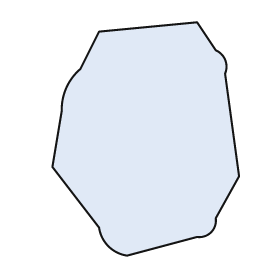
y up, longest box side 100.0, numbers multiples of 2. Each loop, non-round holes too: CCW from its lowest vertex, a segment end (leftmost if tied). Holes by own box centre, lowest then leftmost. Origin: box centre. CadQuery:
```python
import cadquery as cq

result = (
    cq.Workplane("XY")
    .moveTo(-8.0, -50.0)
    .lineTo(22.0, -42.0)
    .threePointArc((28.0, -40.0), (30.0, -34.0))
    .lineTo(40.0, -16.0)
    .lineTo(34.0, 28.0)
    .threePointArc((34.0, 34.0), (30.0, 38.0))
    .lineTo(22.0, 50.0)
    .lineTo(-20.0, 46.0)
    .lineTo(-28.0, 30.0)
    .threePointArc((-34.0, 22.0), (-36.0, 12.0))
    .lineTo(-40.0, -12.0)
    .lineTo(-20.0, -38.0)
    .threePointArc((-16.0, -46.0), (-8.0, -50.0))
    .close()
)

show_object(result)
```